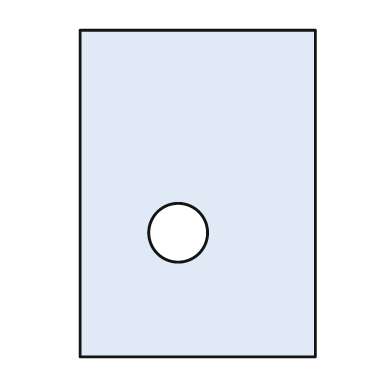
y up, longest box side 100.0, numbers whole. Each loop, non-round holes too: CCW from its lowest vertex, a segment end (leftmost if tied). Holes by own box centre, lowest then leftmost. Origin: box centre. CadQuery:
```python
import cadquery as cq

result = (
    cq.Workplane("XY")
    .moveTo(-36.0, -50.0)
    .lineTo(36.0, -50.0)
    .lineTo(36.0, 50.0)
    .lineTo(-36.0, 50.0)
    .close()
    .moveTo(-6.0, -12.0)
    .circle(9.0)
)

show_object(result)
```